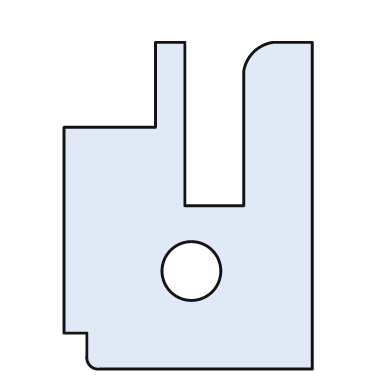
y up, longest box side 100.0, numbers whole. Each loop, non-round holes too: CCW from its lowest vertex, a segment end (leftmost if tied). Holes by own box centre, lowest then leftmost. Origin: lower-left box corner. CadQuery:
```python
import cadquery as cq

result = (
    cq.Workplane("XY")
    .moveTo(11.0, 0.0)
    .lineTo(76.0, 0.0)
    .lineTo(76.0, 100.0)
    .lineTo(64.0, 100.0)
    .threePointArc((58.0, 97.0), (55.0, 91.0))
    .lineTo(55.0, 50.0)
    .lineTo(37.0, 50.0)
    .lineTo(37.0, 100.0)
    .lineTo(28.0, 100.0)
    .lineTo(28.0, 74.0)
    .lineTo(0.0, 74.0)
    .lineTo(0.0, 11.0)
    .lineTo(7.0, 11.0)
    .lineTo(7.0, 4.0)
    .threePointArc((8.0, 1.0), (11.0, 0.0))
    .close()
    .moveTo(39.0, 30.0)
    .circle(9.0)
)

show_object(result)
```